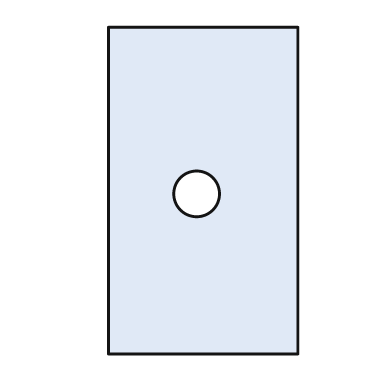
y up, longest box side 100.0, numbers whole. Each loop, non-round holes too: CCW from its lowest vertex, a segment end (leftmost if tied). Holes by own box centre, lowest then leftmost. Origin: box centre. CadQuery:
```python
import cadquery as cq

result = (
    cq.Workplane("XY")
    .moveTo(-29.0, -50.0)
    .lineTo(29.0, -50.0)
    .lineTo(29.0, 50.0)
    .lineTo(-29.0, 50.0)
    .close()
    .moveTo(-2.0, -1.0)
    .circle(7.0)
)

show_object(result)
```